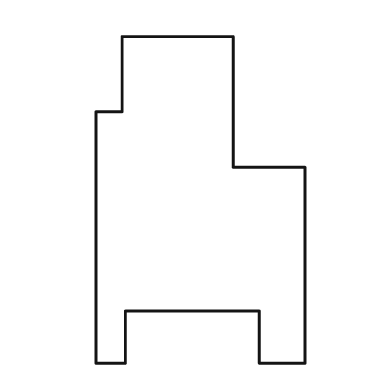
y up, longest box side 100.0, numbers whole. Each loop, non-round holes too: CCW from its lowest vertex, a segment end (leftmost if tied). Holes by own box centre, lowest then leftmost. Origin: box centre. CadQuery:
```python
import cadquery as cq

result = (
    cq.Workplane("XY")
    .moveTo(-32.0, -50.0)
    .lineTo(-23.0, -50.0)
    .lineTo(-23.0, -34.0)
    .lineTo(18.0, -34.0)
    .lineTo(18.0, -50.0)
    .lineTo(32.0, -50.0)
    .lineTo(32.0, 10.0)
    .lineTo(10.0, 10.0)
    .lineTo(10.0, 50.0)
    .lineTo(-24.0, 50.0)
    .lineTo(-24.0, 27.0)
    .lineTo(-32.0, 27.0)
    .close()
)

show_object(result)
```